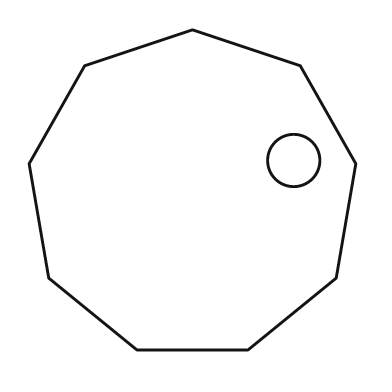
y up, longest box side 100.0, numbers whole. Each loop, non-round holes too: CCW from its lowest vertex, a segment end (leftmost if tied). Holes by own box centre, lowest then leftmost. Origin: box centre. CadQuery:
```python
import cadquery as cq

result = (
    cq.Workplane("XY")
    .moveTo(-17.0, -49.0)
    .lineTo(17.0, -49.0)
    .lineTo(44.0, -27.0)
    .lineTo(50.0, 8.0)
    .lineTo(33.0, 38.0)
    .lineTo(0.0, 49.0)
    .lineTo(-33.0, 38.0)
    .lineTo(-50.0, 8.0)
    .lineTo(-44.0, -27.0)
    .close()
    .moveTo(31.0, 9.0)
    .circle(8.0)
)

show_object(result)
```